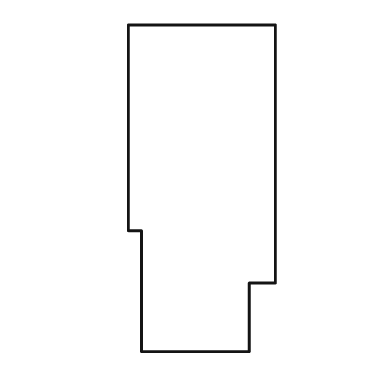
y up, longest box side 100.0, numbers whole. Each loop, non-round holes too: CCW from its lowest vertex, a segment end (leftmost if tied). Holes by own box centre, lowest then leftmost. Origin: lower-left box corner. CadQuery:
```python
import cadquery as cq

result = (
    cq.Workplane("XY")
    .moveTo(4.0, 0.0)
    .lineTo(37.0, 0.0)
    .lineTo(37.0, 21.0)
    .lineTo(45.0, 21.0)
    .lineTo(45.0, 100.0)
    .lineTo(0.0, 100.0)
    .lineTo(0.0, 37.0)
    .lineTo(4.0, 37.0)
    .close()
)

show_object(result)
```